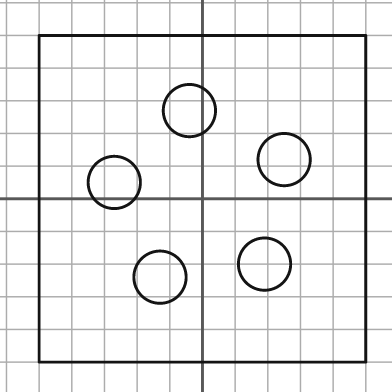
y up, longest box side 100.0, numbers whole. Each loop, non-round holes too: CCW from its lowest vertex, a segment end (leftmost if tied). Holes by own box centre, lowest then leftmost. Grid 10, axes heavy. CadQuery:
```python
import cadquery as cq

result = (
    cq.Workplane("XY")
    .moveTo(-50.0, -50.0)
    .lineTo(50.0, -50.0)
    .lineTo(50.0, 50.0)
    .lineTo(-50.0, 50.0)
    .close()
    .moveTo(-13.0, -24.0)
    .circle(8.0)
    .moveTo(19.0, -20.0)
    .circle(8.0)
    .moveTo(-27.0, 5.0)
    .circle(8.0)
    .moveTo(25.0, 12.0)
    .circle(8.0)
    .moveTo(-4.0, 27.0)
    .circle(8.0)
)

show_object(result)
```